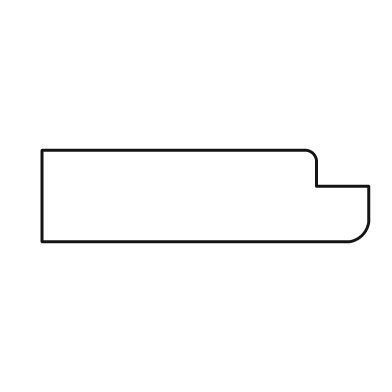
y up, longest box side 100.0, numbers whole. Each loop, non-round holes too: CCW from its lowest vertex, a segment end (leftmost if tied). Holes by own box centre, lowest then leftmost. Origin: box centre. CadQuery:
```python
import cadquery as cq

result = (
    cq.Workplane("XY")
    .moveTo(-50.0, -14.0)
    .lineTo(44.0, -14.0)
    .threePointArc((48.0, -12.0), (50.0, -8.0))
    .lineTo(50.0, 3.0)
    .lineTo(34.0, 3.0)
    .lineTo(34.0, 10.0)
    .threePointArc((33.0, 13.0), (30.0, 14.0))
    .lineTo(-50.0, 14.0)
    .close()
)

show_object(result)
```